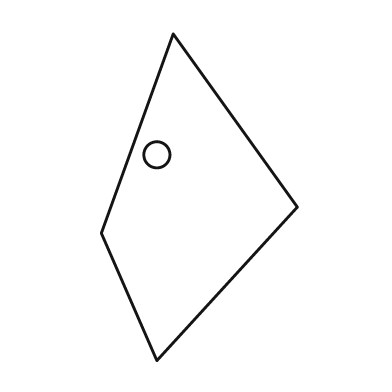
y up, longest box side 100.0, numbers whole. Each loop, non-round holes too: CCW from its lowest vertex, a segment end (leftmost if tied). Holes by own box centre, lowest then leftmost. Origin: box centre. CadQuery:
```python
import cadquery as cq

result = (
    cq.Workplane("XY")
    .moveTo(-13.0, -50.0)
    .lineTo(30.0, -3.0)
    .lineTo(-8.0, 50.0)
    .lineTo(-30.0, -11.0)
    .close()
    .moveTo(-13.0, 13.0)
    .circle(4.0)
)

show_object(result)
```